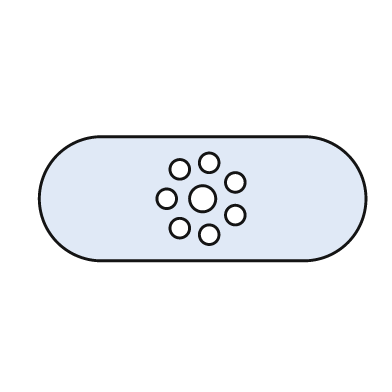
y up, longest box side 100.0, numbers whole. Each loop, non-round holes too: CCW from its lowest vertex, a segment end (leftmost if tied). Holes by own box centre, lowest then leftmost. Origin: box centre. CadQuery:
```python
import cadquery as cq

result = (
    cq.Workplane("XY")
    .moveTo(-31.0, -19.0)
    .lineTo(31.0, -19.0)
    .threePointArc((50.0, 0.0), (31.0, 19.0))
    .lineTo(-31.0, 19.0)
    .threePointArc((-50.0, 0.0), (-31.0, -19.0))
    .close()
    .moveTo(2.0, -11.0)
    .circle(3.0)
    .moveTo(-7.0, -9.0)
    .circle(3.0)
    .moveTo(10.0, -5.0)
    .circle(3.0)
    .moveTo(-11.0, 0.0)
    .circle(3.0)
    .moveTo(0.0, 0.0)
    .circle(4.0)
    .moveTo(10.0, 5.0)
    .circle(3.0)
    .moveTo(-7.0, 9.0)
    .circle(3.0)
    .moveTo(2.0, 11.0)
    .circle(3.0)
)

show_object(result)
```